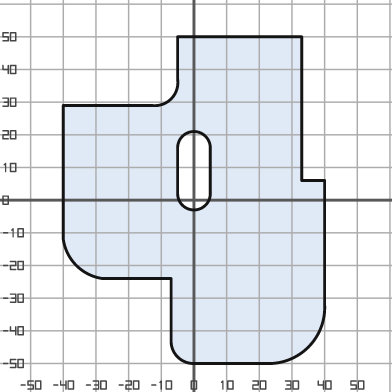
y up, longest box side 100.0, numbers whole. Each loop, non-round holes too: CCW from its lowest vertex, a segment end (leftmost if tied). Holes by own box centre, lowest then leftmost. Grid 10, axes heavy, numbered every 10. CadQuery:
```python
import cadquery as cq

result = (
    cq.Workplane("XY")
    .moveTo(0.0, -50.0)
    .lineTo(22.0, -50.0)
    .threePointArc((35.0, -45.0), (40.0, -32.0))
    .lineTo(40.0, 6.0)
    .lineTo(33.0, 6.0)
    .lineTo(33.0, 50.0)
    .lineTo(-5.0, 50.0)
    .lineTo(-5.0, 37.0)
    .threePointArc((-7.0, 31.0), (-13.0, 29.0))
    .lineTo(-40.0, 29.0)
    .lineTo(-40.0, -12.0)
    .threePointArc((-36.0, -20.0), (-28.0, -24.0))
    .lineTo(-7.0, -24.0)
    .lineTo(-7.0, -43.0)
    .threePointArc((-5.0, -48.0), (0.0, -50.0))
    .close()
    .moveTo(-5.0, 2.0)
    .threePointArc((0.0, -3.0), (5.0, 2.0))
    .lineTo(5.0, 16.0)
    .threePointArc((0.0, 21.0), (-5.0, 16.0))
    .close()
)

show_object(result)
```